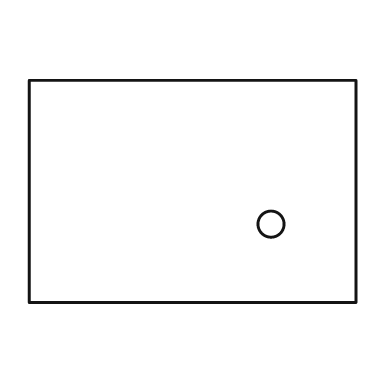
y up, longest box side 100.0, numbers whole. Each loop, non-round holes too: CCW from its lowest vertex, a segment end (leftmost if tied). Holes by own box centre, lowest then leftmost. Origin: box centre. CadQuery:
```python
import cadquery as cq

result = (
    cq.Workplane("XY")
    .moveTo(-50.0, -34.0)
    .lineTo(50.0, -34.0)
    .lineTo(50.0, 34.0)
    .lineTo(-50.0, 34.0)
    .close()
    .moveTo(24.0, -10.0)
    .circle(4.0)
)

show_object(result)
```